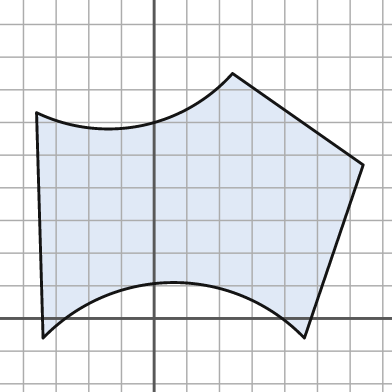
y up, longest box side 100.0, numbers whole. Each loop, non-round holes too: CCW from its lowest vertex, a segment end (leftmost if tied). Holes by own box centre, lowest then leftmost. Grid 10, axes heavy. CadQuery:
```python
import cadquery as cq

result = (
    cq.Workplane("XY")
    .moveTo(-34.0, -6.0)
    .threePointArc((6.0, 11.0), (46.0, -6.0))
    .lineTo(64.0, 47.0)
    .lineTo(24.0, 75.0)
    .threePointArc((-4.0, 59.0), (-36.0, 63.0))
    .close()
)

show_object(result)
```